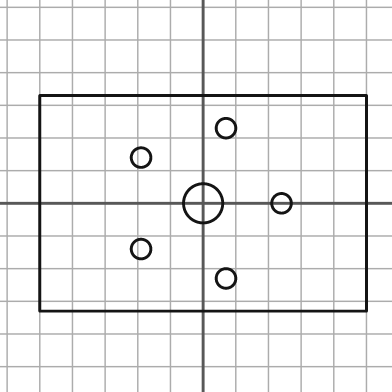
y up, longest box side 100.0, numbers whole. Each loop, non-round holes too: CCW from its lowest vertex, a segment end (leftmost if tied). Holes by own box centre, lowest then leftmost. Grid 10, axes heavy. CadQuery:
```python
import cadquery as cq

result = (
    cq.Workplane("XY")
    .moveTo(-50.0, -33.0)
    .lineTo(50.0, -33.0)
    .lineTo(50.0, 33.0)
    .lineTo(-50.0, 33.0)
    .close()
    .moveTo(7.0, -23.0)
    .circle(3.0)
    .moveTo(-19.0, -14.0)
    .circle(3.0)
    .moveTo(0.0, 0.0)
    .circle(6.0)
    .moveTo(24.0, 0.0)
    .circle(3.0)
    .moveTo(-19.0, 14.0)
    .circle(3.0)
    .moveTo(7.0, 23.0)
    .circle(3.0)
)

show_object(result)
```